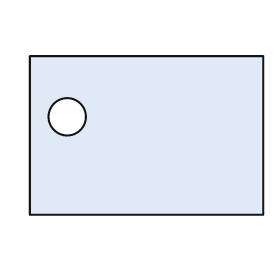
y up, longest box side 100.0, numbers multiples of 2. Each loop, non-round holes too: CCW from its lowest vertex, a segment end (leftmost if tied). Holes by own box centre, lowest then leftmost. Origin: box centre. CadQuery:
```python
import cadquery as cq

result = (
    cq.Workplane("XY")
    .moveTo(-50.0, -34.0)
    .lineTo(50.0, -34.0)
    .lineTo(50.0, 34.0)
    .lineTo(-50.0, 34.0)
    .close()
    .moveTo(-34.0, 8.0)
    .circle(8.0)
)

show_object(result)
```